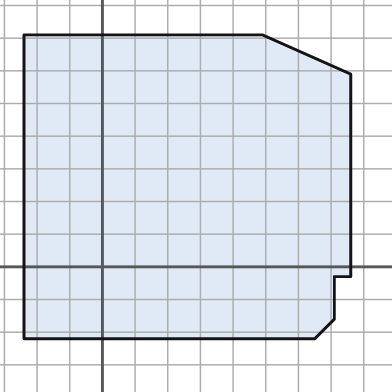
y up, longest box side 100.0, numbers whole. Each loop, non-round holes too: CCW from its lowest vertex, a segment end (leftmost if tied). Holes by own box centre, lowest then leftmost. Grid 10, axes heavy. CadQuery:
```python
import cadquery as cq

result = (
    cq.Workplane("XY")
    .moveTo(-24.0, -22.0)
    .lineTo(65.0, -22.0)
    .lineTo(71.0, -16.0)
    .lineTo(71.0, -3.0)
    .lineTo(76.0, -3.0)
    .lineTo(76.0, 59.0)
    .lineTo(49.0, 71.0)
    .lineTo(-24.0, 71.0)
    .close()
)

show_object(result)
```